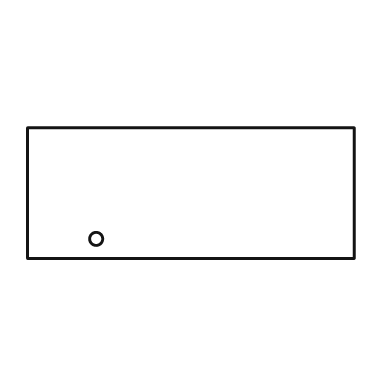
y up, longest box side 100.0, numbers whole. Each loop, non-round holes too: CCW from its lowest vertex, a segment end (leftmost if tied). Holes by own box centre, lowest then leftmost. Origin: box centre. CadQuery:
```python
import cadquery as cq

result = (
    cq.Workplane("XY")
    .moveTo(-50.0, -20.0)
    .lineTo(50.0, -20.0)
    .lineTo(50.0, 20.0)
    .lineTo(-50.0, 20.0)
    .close()
    .moveTo(-29.0, -14.0)
    .circle(2.0)
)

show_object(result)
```